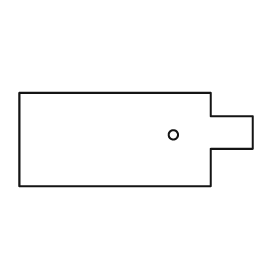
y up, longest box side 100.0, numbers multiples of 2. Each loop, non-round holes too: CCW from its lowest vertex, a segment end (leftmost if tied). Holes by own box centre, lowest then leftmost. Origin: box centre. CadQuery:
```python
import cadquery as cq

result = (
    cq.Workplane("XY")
    .moveTo(-50.0, -20.0)
    .lineTo(32.0, -20.0)
    .lineTo(32.0, -4.0)
    .lineTo(50.0, -4.0)
    .lineTo(50.0, 10.0)
    .lineTo(32.0, 10.0)
    .lineTo(32.0, 20.0)
    .lineTo(-50.0, 20.0)
    .close()
    .moveTo(16.0, 2.0)
    .circle(2.0)
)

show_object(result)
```